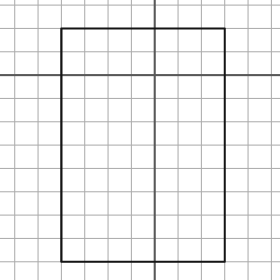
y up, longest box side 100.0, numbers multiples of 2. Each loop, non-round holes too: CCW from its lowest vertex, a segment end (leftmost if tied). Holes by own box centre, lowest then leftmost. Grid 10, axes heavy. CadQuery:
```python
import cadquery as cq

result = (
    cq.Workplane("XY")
    .moveTo(-40.0, -80.0)
    .lineTo(30.0, -80.0)
    .lineTo(30.0, 20.0)
    .lineTo(-40.0, 20.0)
    .close()
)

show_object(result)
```